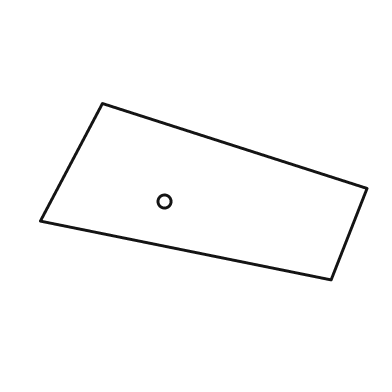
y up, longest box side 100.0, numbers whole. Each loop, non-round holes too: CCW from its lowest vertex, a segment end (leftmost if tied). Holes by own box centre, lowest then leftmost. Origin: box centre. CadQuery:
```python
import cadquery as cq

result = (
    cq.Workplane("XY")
    .moveTo(39.0, -27.0)
    .lineTo(50.0, 1.0)
    .lineTo(-31.0, 27.0)
    .lineTo(-50.0, -9.0)
    .close()
    .moveTo(-12.0, -3.0)
    .circle(2.0)
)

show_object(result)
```